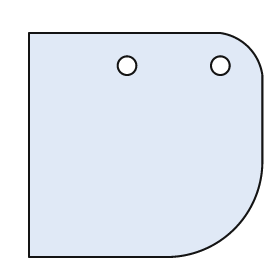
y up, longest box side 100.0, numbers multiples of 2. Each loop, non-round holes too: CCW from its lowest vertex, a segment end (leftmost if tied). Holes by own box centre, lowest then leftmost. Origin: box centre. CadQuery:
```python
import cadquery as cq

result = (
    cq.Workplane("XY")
    .moveTo(-50.0, -48.0)
    .lineTo(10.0, -48.0)
    .threePointArc((38.0, -36.0), (50.0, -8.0))
    .lineTo(50.0, 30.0)
    .threePointArc((44.0, 42.0), (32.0, 48.0))
    .lineTo(-50.0, 48.0)
    .close()
    .moveTo(-8.0, 34.0)
    .circle(4.0)
    .moveTo(32.0, 34.0)
    .circle(4.0)
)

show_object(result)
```